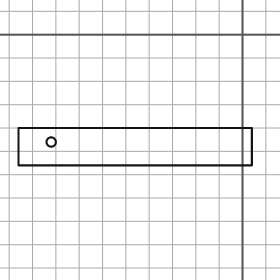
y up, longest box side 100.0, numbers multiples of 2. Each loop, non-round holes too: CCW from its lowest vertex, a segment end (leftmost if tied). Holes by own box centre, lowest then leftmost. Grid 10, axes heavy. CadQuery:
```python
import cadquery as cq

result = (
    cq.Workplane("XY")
    .moveTo(-96.0, -56.0)
    .lineTo(4.0, -56.0)
    .lineTo(4.0, -40.0)
    .lineTo(-96.0, -40.0)
    .close()
    .moveTo(-82.0, -46.0)
    .circle(2.0)
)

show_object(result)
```